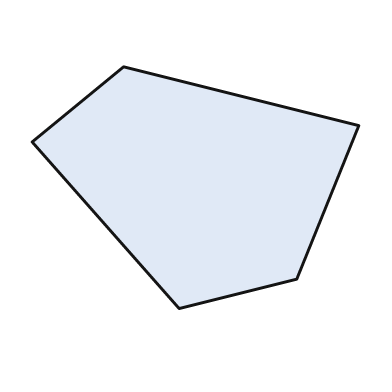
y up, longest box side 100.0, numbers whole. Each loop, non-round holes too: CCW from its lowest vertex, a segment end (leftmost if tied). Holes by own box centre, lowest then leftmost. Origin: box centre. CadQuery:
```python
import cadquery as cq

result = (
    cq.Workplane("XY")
    .moveTo(-5.0, -37.0)
    .lineTo(31.0, -28.0)
    .lineTo(50.0, 19.0)
    .lineTo(-22.0, 37.0)
    .lineTo(-50.0, 14.0)
    .close()
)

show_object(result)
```